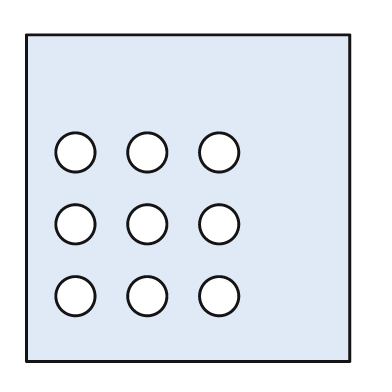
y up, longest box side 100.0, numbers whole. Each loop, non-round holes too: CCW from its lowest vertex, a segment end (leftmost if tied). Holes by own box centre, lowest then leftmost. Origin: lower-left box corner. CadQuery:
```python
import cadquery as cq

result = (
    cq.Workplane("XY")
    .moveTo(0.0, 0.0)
    .lineTo(99.0, 0.0)
    .lineTo(99.0, 100.0)
    .lineTo(0.0, 100.0)
    .close()
    .moveTo(15.0, 20.0)
    .circle(6.0)
    .moveTo(37.0, 20.0)
    .circle(6.0)
    .moveTo(59.0, 20.0)
    .circle(6.0)
    .moveTo(15.0, 42.0)
    .circle(6.0)
    .moveTo(37.0, 42.0)
    .circle(6.0)
    .moveTo(59.0, 42.0)
    .circle(6.0)
    .moveTo(15.0, 64.0)
    .circle(6.0)
    .moveTo(37.0, 64.0)
    .circle(6.0)
    .moveTo(59.0, 64.0)
    .circle(6.0)
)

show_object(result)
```